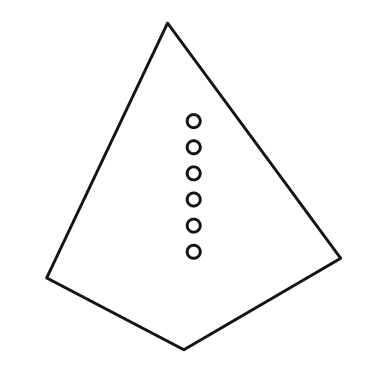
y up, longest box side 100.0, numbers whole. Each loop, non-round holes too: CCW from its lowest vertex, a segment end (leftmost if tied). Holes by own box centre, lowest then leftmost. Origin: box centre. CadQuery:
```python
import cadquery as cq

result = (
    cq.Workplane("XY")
    .moveTo(-3.0, -50.0)
    .lineTo(45.0, -22.0)
    .lineTo(-8.0, 50.0)
    .lineTo(-45.0, -28.0)
    .close()
    .moveTo(0.0, -20.0)
    .circle(2.0)
    .moveTo(0.0, -12.0)
    .circle(2.0)
    .moveTo(0.0, -4.0)
    .circle(2.0)
    .moveTo(0.0, 4.0)
    .circle(2.0)
    .moveTo(0.0, 12.0)
    .circle(2.0)
    .moveTo(0.0, 20.0)
    .circle(2.0)
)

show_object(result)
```